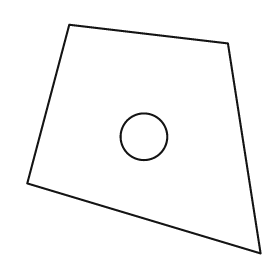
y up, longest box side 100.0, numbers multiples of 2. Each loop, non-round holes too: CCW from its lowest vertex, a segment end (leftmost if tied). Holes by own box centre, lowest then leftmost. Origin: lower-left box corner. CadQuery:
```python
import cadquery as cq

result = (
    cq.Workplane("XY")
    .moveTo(100.0, 0.0)
    .lineTo(86.0, 90.0)
    .lineTo(18.0, 98.0)
    .lineTo(0.0, 30.0)
    .close()
    .moveTo(50.0, 50.0)
    .circle(10.0)
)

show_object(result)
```